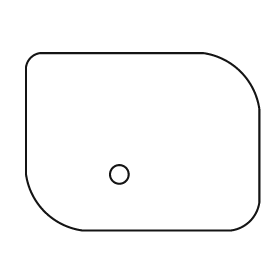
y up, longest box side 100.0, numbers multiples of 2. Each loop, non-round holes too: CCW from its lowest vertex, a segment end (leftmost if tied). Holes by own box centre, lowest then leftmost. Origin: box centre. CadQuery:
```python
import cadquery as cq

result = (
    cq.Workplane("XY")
    .moveTo(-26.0, -38.0)
    .lineTo(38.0, -38.0)
    .threePointArc((46.0, -34.0), (50.0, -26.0))
    .lineTo(50.0, 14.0)
    .threePointArc((42.0, 30.0), (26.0, 38.0))
    .lineTo(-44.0, 38.0)
    .threePointArc((-48.0, 36.0), (-50.0, 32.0))
    .lineTo(-50.0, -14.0)
    .threePointArc((-42.0, -30.0), (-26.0, -38.0))
    .close()
    .moveTo(-10.0, -14.0)
    .circle(4.0)
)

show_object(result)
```